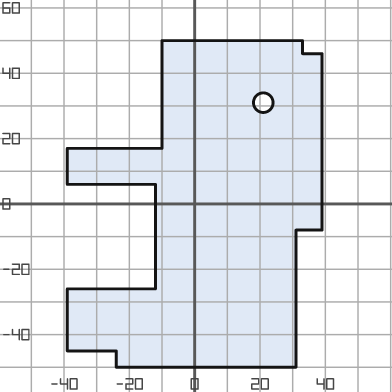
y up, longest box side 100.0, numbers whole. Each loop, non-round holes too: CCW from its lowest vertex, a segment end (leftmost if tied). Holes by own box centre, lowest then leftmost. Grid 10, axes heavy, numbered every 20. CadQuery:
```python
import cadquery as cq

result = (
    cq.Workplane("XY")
    .moveTo(-24.0, -50.0)
    .lineTo(31.0, -50.0)
    .lineTo(31.0, -8.0)
    .lineTo(39.0, -8.0)
    .lineTo(39.0, 46.0)
    .lineTo(33.0, 46.0)
    .lineTo(33.0, 50.0)
    .lineTo(-10.0, 50.0)
    .lineTo(-10.0, 17.0)
    .lineTo(-39.0, 17.0)
    .lineTo(-39.0, 6.0)
    .lineTo(-12.0, 6.0)
    .lineTo(-12.0, -26.0)
    .lineTo(-39.0, -26.0)
    .lineTo(-39.0, -45.0)
    .lineTo(-24.0, -45.0)
    .close()
    .moveTo(21.0, 31.0)
    .circle(3.0)
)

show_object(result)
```